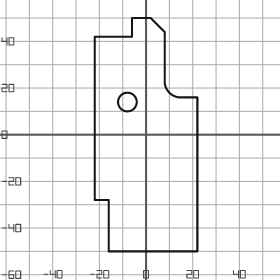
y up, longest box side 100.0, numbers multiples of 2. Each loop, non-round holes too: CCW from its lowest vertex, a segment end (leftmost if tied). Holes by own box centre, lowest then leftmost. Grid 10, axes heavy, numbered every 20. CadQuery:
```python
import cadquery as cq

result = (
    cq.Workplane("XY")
    .moveTo(-16.0, -50.0)
    .lineTo(22.0, -50.0)
    .lineTo(22.0, 16.0)
    .lineTo(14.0, 16.0)
    .threePointArc((10.0, 18.0), (8.0, 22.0))
    .lineTo(8.0, 44.0)
    .lineTo(2.0, 50.0)
    .lineTo(-6.0, 50.0)
    .lineTo(-6.0, 42.0)
    .lineTo(-22.0, 42.0)
    .lineTo(-22.0, -28.0)
    .lineTo(-16.0, -28.0)
    .close()
    .moveTo(-8.0, 14.0)
    .circle(4.0)
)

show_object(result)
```